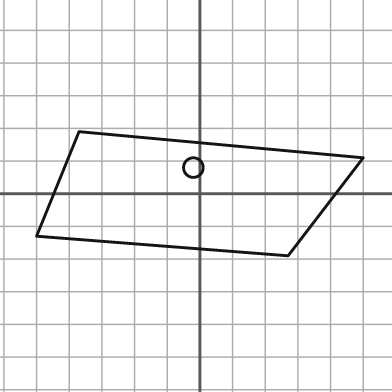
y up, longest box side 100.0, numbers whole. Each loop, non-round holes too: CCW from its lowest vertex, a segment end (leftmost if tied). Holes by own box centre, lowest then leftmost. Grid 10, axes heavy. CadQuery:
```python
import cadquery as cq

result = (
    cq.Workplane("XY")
    .moveTo(27.0, -19.0)
    .lineTo(50.0, 11.0)
    .lineTo(-37.0, 19.0)
    .lineTo(-50.0, -13.0)
    .close()
    .moveTo(-2.0, 8.0)
    .circle(3.0)
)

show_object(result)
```